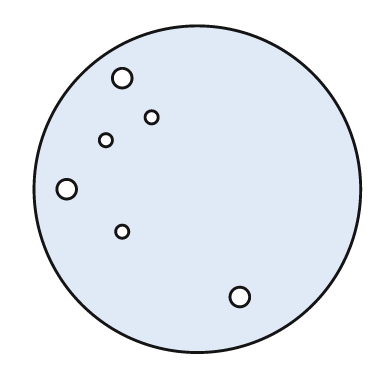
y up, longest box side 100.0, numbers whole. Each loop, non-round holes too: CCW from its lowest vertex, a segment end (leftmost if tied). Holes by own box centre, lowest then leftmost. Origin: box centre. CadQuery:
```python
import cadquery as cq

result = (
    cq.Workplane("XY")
    .moveTo(0.0, 0.0)
    .circle(50.0)
    .moveTo(13.0, -33.0)
    .circle(3.0)
    .moveTo(-23.0, -13.0)
    .circle(2.0)
    .moveTo(-40.0, 0.0)
    .circle(3.0)
    .moveTo(-28.0, 15.0)
    .circle(2.0)
    .moveTo(-14.0, 22.0)
    .circle(2.0)
    .moveTo(-23.0, 34.0)
    .circle(3.0)
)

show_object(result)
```